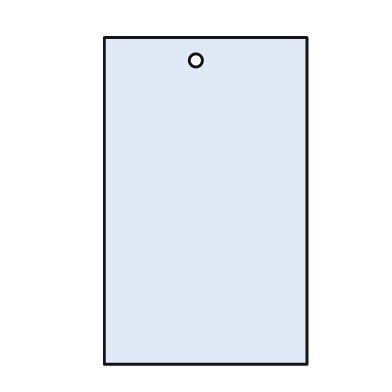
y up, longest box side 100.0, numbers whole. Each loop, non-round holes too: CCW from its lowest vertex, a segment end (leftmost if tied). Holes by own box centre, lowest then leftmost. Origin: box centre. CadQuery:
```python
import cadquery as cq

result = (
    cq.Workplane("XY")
    .moveTo(-31.0, -50.0)
    .lineTo(31.0, -50.0)
    .lineTo(31.0, 50.0)
    .lineTo(-31.0, 50.0)
    .close()
    .moveTo(-3.0, 43.0)
    .circle(2.0)
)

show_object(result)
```